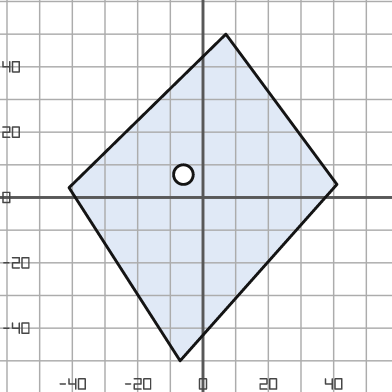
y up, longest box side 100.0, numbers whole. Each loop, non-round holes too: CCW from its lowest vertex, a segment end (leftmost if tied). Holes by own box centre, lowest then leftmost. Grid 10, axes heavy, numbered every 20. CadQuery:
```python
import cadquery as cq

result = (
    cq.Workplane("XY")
    .moveTo(-7.0, -50.0)
    .lineTo(41.0, 4.0)
    .lineTo(7.0, 50.0)
    .lineTo(-41.0, 3.0)
    .close()
    .moveTo(-6.0, 7.0)
    .circle(3.0)
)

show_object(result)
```